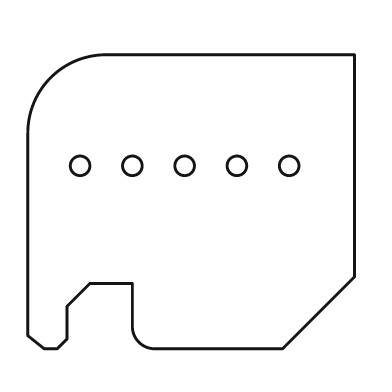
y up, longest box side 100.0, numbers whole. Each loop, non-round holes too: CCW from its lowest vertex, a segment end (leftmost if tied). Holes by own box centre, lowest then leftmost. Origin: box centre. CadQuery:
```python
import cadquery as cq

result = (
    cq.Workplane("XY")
    .moveTo(-45.0, -45.0)
    .lineTo(-41.0, -45.0)
    .lineTo(-38.0, -42.0)
    .lineTo(-38.0, -32.0)
    .lineTo(-31.0, -25.0)
    .lineTo(-18.0, -25.0)
    .lineTo(-18.0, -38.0)
    .threePointArc((-16.0, -43.0), (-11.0, -45.0))
    .lineTo(28.0, -45.0)
    .lineTo(50.0, -23.0)
    .lineTo(50.0, 45.0)
    .lineTo(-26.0, 45.0)
    .threePointArc((-43.0, 38.0), (-50.0, 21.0))
    .lineTo(-50.0, -41.0)
    .close()
    .moveTo(-34.0, 11.0)
    .circle(3.0)
    .moveTo(-18.0, 11.0)
    .circle(3.0)
    .moveTo(-2.0, 11.0)
    .circle(3.0)
    .moveTo(14.0, 11.0)
    .circle(3.0)
    .moveTo(30.0, 11.0)
    .circle(3.0)
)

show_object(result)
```